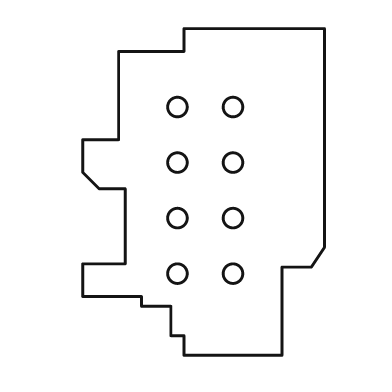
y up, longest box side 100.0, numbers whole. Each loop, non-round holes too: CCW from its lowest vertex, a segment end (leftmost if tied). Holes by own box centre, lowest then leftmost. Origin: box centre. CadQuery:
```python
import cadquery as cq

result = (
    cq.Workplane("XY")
    .moveTo(-6.0, -50.0)
    .lineTo(24.0, -50.0)
    .lineTo(24.0, -23.0)
    .lineTo(33.0, -23.0)
    .lineTo(37.0, -17.0)
    .lineTo(37.0, 50.0)
    .lineTo(-6.0, 50.0)
    .lineTo(-6.0, 43.0)
    .lineTo(-26.0, 43.0)
    .lineTo(-26.0, 16.0)
    .lineTo(-37.0, 16.0)
    .lineTo(-37.0, 6.0)
    .lineTo(-32.0, 1.0)
    .lineTo(-24.0, 1.0)
    .lineTo(-24.0, -22.0)
    .lineTo(-37.0, -22.0)
    .lineTo(-37.0, -32.0)
    .lineTo(-19.0, -32.0)
    .lineTo(-19.0, -35.0)
    .lineTo(-10.0, -35.0)
    .lineTo(-10.0, -44.0)
    .lineTo(-6.0, -44.0)
    .close()
    .moveTo(-8.0, -25.0)
    .circle(3.0)
    .moveTo(9.0, -25.0)
    .circle(3.0)
    .moveTo(-8.0, -8.0)
    .circle(3.0)
    .moveTo(9.0, -8.0)
    .circle(3.0)
    .moveTo(-8.0, 9.0)
    .circle(3.0)
    .moveTo(9.0, 9.0)
    .circle(3.0)
    .moveTo(-8.0, 26.0)
    .circle(3.0)
    .moveTo(9.0, 26.0)
    .circle(3.0)
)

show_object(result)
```